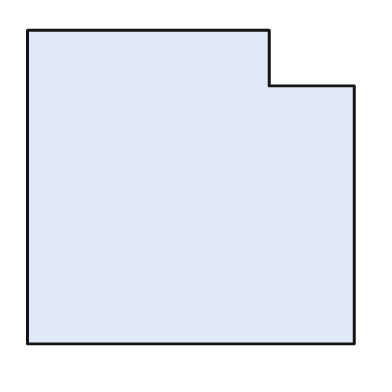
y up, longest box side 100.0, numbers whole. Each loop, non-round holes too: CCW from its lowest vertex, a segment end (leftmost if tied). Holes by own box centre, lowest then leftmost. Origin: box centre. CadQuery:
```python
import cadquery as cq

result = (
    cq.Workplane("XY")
    .moveTo(-50.0, -48.0)
    .lineTo(50.0, -48.0)
    .lineTo(50.0, 31.0)
    .lineTo(24.0, 31.0)
    .lineTo(24.0, 48.0)
    .lineTo(-50.0, 48.0)
    .close()
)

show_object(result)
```